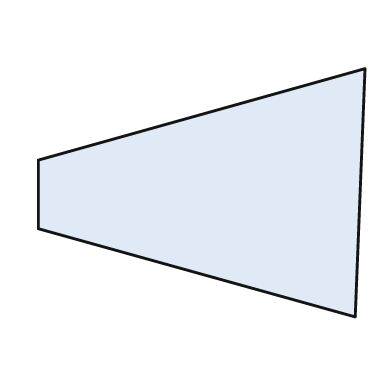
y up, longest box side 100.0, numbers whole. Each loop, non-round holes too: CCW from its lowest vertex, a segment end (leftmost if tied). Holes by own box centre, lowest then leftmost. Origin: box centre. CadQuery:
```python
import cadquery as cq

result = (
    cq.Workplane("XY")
    .moveTo(47.0, -38.0)
    .lineTo(50.0, 38.0)
    .lineTo(-50.0, 10.0)
    .lineTo(-50.0, -11.0)
    .close()
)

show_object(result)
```